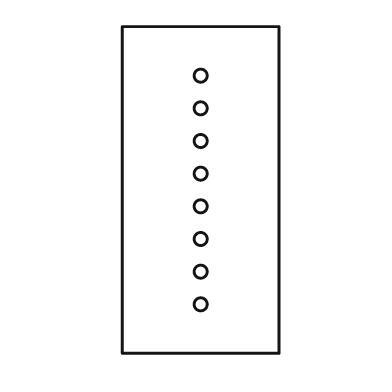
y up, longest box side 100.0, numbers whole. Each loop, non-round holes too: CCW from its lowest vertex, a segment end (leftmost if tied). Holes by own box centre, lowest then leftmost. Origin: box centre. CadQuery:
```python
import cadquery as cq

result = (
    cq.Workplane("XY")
    .moveTo(-24.0, -50.0)
    .lineTo(24.0, -50.0)
    .lineTo(24.0, 50.0)
    .lineTo(-24.0, 50.0)
    .close()
    .moveTo(0.0, -35.0)
    .circle(2.0)
    .moveTo(0.0, -25.0)
    .circle(2.0)
    .moveTo(0.0, -15.0)
    .circle(2.0)
    .moveTo(0.0, -5.0)
    .circle(2.0)
    .moveTo(0.0, 5.0)
    .circle(2.0)
    .moveTo(0.0, 15.0)
    .circle(2.0)
    .moveTo(0.0, 25.0)
    .circle(2.0)
    .moveTo(0.0, 35.0)
    .circle(2.0)
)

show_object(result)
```